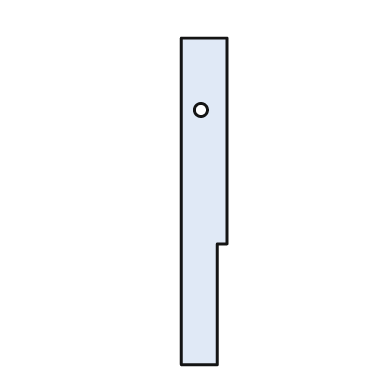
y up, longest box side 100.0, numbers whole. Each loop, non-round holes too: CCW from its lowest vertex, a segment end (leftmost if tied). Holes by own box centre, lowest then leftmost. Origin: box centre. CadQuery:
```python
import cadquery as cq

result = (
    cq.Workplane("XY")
    .moveTo(-7.0, -50.0)
    .lineTo(4.0, -50.0)
    .lineTo(4.0, -13.0)
    .lineTo(7.0, -13.0)
    .lineTo(7.0, 50.0)
    .lineTo(-7.0, 50.0)
    .close()
    .moveTo(-1.0, 28.0)
    .circle(2.0)
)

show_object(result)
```